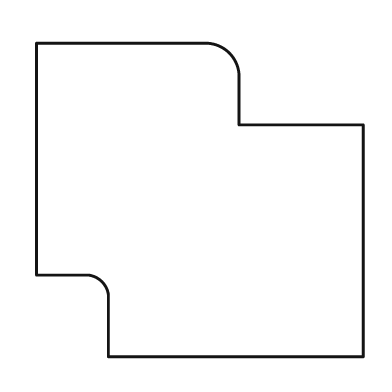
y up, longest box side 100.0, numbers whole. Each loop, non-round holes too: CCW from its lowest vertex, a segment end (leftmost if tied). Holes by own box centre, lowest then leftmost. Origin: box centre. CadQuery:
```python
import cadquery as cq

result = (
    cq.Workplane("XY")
    .moveTo(-28.0, -48.0)
    .lineTo(50.0, -48.0)
    .lineTo(50.0, 23.0)
    .lineTo(12.0, 23.0)
    .lineTo(12.0, 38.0)
    .threePointArc((9.0, 45.0), (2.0, 48.0))
    .lineTo(-50.0, 48.0)
    .lineTo(-50.0, -23.0)
    .lineTo(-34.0, -23.0)
    .threePointArc((-30.0, -25.0), (-28.0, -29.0))
    .close()
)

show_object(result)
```